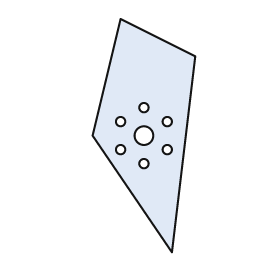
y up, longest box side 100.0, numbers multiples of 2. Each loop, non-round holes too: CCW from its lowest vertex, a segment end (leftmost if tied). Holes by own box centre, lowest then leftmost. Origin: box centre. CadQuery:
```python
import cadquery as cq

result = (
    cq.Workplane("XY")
    .moveTo(12.0, -50.0)
    .lineTo(22.0, 34.0)
    .lineTo(-10.0, 50.0)
    .lineTo(-22.0, 0.0)
    .close()
    .moveTo(0.0, -12.0)
    .circle(2.0)
    .moveTo(-10.0, -6.0)
    .circle(2.0)
    .moveTo(10.0, -6.0)
    .circle(2.0)
    .moveTo(0.0, 0.0)
    .circle(4.0)
    .moveTo(-10.0, 6.0)
    .circle(2.0)
    .moveTo(10.0, 6.0)
    .circle(2.0)
    .moveTo(0.0, 12.0)
    .circle(2.0)
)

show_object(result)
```